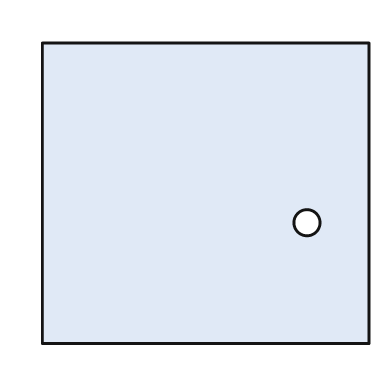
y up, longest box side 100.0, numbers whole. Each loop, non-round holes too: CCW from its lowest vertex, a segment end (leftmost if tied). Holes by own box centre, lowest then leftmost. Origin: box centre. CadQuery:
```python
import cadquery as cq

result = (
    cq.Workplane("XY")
    .moveTo(-50.0, -46.0)
    .lineTo(50.0, -46.0)
    .lineTo(50.0, 46.0)
    .lineTo(-50.0, 46.0)
    .close()
    .moveTo(31.0, -9.0)
    .circle(4.0)
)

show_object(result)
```